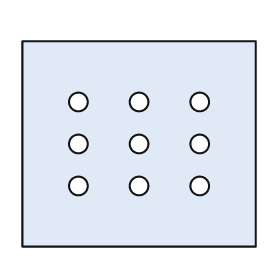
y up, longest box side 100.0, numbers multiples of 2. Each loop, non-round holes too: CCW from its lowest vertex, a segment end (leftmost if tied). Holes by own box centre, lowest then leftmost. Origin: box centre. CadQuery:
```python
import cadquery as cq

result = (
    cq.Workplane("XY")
    .moveTo(-50.0, -44.0)
    .lineTo(50.0, -44.0)
    .lineTo(50.0, 44.0)
    .lineTo(-50.0, 44.0)
    .close()
    .moveTo(-26.0, -18.0)
    .circle(4.0)
    .moveTo(0.0, -18.0)
    .circle(4.0)
    .moveTo(26.0, -18.0)
    .circle(4.0)
    .moveTo(-26.0, 0.0)
    .circle(4.0)
    .moveTo(0.0, 0.0)
    .circle(4.0)
    .moveTo(26.0, 0.0)
    .circle(4.0)
    .moveTo(-26.0, 18.0)
    .circle(4.0)
    .moveTo(0.0, 18.0)
    .circle(4.0)
    .moveTo(26.0, 18.0)
    .circle(4.0)
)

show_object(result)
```